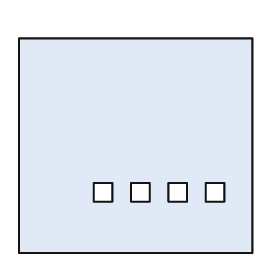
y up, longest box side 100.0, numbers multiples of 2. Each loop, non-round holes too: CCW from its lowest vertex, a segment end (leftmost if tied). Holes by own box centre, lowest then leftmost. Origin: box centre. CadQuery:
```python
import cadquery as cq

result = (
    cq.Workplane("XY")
    .moveTo(-50.0, -46.0)
    .lineTo(50.0, -46.0)
    .lineTo(50.0, 46.0)
    .lineTo(-50.0, 46.0)
    .close()
    .moveTo(-18.0, -24.0)
    .lineTo(-10.0, -24.0)
    .lineTo(-10.0, -16.0)
    .lineTo(-18.0, -16.0)
    .close()
    .moveTo(-2.0, -24.0)
    .lineTo(6.0, -24.0)
    .lineTo(6.0, -16.0)
    .lineTo(-2.0, -16.0)
    .close()
    .moveTo(14.0, -24.0)
    .lineTo(22.0, -24.0)
    .lineTo(22.0, -16.0)
    .lineTo(14.0, -16.0)
    .close()
    .moveTo(30.0, -24.0)
    .lineTo(38.0, -24.0)
    .lineTo(38.0, -16.0)
    .lineTo(30.0, -16.0)
    .close()
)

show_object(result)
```